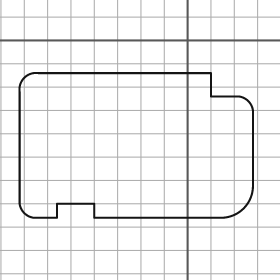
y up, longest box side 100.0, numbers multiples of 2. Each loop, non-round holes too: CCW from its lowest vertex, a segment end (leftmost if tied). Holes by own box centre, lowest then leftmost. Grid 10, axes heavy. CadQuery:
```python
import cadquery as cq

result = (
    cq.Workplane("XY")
    .moveTo(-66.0, -76.0)
    .lineTo(-56.0, -76.0)
    .lineTo(-56.0, -70.0)
    .lineTo(-40.0, -70.0)
    .lineTo(-40.0, -76.0)
    .lineTo(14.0, -76.0)
    .threePointArc((24.0, -72.0), (28.0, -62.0))
    .lineTo(28.0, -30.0)
    .threePointArc((26.0, -26.0), (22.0, -24.0))
    .lineTo(10.0, -24.0)
    .lineTo(10.0, -14.0)
    .lineTo(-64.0, -14.0)
    .threePointArc((-70.0, -16.0), (-72.0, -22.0))
    .lineTo(-72.0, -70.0)
    .threePointArc((-70.0, -74.0), (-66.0, -76.0))
    .close()
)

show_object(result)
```